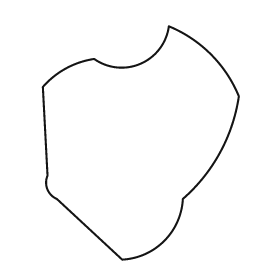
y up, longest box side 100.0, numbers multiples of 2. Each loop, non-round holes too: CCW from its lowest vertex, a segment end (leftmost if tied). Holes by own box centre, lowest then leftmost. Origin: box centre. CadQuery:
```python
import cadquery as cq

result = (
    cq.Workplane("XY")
    .moveTo(-8.0, -50.0)
    .threePointArc((10.0, -42.0), (18.0, -24.0))
    .threePointArc((34.0, -4.0), (42.0, 20.0))
    .threePointArc((30.0, 38.0), (12.0, 50.0))
    .threePointArc((0.0, 34.0), (-20.0, 36.0))
    .threePointArc((-32.0, 32.0), (-42.0, 24.0))
    .lineTo(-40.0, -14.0)
    .threePointArc((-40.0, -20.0), (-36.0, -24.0))
    .close()
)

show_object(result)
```